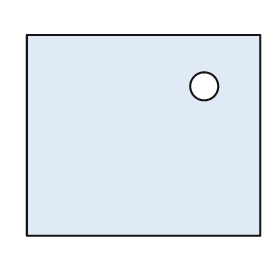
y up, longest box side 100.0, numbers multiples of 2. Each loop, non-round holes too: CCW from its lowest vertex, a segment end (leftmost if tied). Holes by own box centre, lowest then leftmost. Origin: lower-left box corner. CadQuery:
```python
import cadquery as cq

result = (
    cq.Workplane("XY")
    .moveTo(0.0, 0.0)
    .lineTo(100.0, 0.0)
    .lineTo(100.0, 86.0)
    .lineTo(0.0, 86.0)
    .close()
    .moveTo(76.0, 64.0)
    .circle(6.0)
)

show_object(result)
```